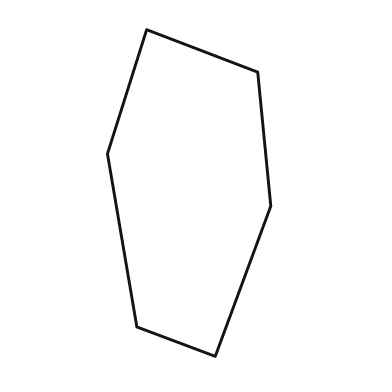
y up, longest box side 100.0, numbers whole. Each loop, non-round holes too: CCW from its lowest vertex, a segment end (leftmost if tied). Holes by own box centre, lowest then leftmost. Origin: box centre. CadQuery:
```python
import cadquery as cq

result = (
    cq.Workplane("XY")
    .moveTo(8.0, -50.0)
    .lineTo(25.0, -4.0)
    .lineTo(21.0, 37.0)
    .lineTo(-13.0, 50.0)
    .lineTo(-25.0, 12.0)
    .lineTo(-16.0, -41.0)
    .close()
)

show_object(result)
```